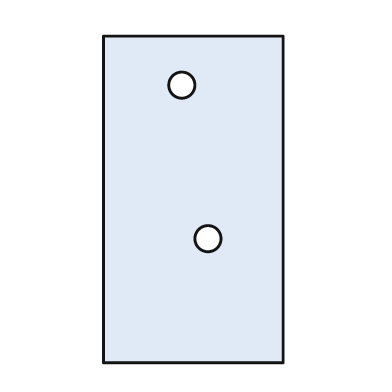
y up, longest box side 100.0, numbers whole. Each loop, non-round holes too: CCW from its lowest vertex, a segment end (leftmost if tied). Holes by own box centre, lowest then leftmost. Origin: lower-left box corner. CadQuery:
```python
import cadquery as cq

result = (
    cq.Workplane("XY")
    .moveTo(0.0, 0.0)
    .lineTo(55.0, 0.0)
    .lineTo(55.0, 100.0)
    .lineTo(0.0, 100.0)
    .close()
    .moveTo(32.0, 38.0)
    .circle(4.0)
    .moveTo(24.0, 85.0)
    .circle(4.0)
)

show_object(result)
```